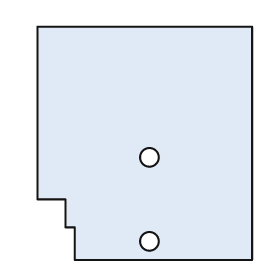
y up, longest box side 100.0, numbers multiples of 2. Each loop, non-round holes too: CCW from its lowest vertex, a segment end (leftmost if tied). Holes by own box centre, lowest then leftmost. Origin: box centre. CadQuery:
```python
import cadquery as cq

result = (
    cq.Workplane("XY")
    .moveTo(-30.0, -50.0)
    .lineTo(46.0, -50.0)
    .lineTo(46.0, 50.0)
    .lineTo(-46.0, 50.0)
    .lineTo(-46.0, -24.0)
    .lineTo(-34.0, -24.0)
    .lineTo(-34.0, -36.0)
    .lineTo(-30.0, -36.0)
    .close()
    .moveTo(2.0, -42.0)
    .circle(4.0)
    .moveTo(2.0, -6.0)
    .circle(4.0)
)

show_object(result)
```